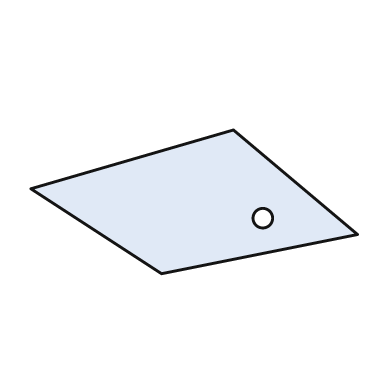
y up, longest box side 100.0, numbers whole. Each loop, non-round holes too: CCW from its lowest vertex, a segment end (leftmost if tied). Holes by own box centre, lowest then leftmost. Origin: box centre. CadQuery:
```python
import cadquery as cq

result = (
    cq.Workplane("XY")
    .moveTo(-10.0, -22.0)
    .lineTo(50.0, -10.0)
    .lineTo(12.0, 22.0)
    .lineTo(-50.0, 4.0)
    .close()
    .moveTo(21.0, -5.0)
    .circle(3.0)
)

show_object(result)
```